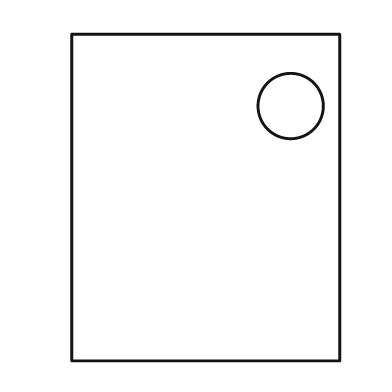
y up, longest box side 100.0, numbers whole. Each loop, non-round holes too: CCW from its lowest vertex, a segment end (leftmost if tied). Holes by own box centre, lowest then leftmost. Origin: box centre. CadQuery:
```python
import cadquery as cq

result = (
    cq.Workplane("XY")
    .moveTo(-41.0, -50.0)
    .lineTo(41.0, -50.0)
    .lineTo(41.0, 50.0)
    .lineTo(-41.0, 50.0)
    .close()
    .moveTo(26.0, 28.0)
    .circle(10.0)
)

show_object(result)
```